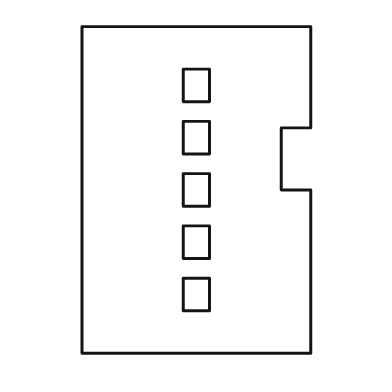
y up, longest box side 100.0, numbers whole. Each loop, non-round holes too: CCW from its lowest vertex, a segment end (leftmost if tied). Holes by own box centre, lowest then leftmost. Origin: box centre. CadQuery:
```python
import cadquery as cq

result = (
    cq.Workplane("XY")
    .moveTo(-35.0, -50.0)
    .lineTo(35.0, -50.0)
    .lineTo(35.0, 0.0)
    .lineTo(26.0, 0.0)
    .lineTo(26.0, 19.0)
    .lineTo(35.0, 19.0)
    .lineTo(35.0, 50.0)
    .lineTo(-35.0, 50.0)
    .close()
    .moveTo(-4.0, -37.0)
    .lineTo(4.0, -37.0)
    .lineTo(4.0, -27.0)
    .lineTo(-4.0, -27.0)
    .close()
    .moveTo(-4.0, -21.0)
    .lineTo(4.0, -21.0)
    .lineTo(4.0, -11.0)
    .lineTo(-4.0, -11.0)
    .close()
    .moveTo(-4.0, -5.0)
    .lineTo(4.0, -5.0)
    .lineTo(4.0, 5.0)
    .lineTo(-4.0, 5.0)
    .close()
    .moveTo(-4.0, 11.0)
    .lineTo(4.0, 11.0)
    .lineTo(4.0, 21.0)
    .lineTo(-4.0, 21.0)
    .close()
    .moveTo(-4.0, 27.0)
    .lineTo(4.0, 27.0)
    .lineTo(4.0, 37.0)
    .lineTo(-4.0, 37.0)
    .close()
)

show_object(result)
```